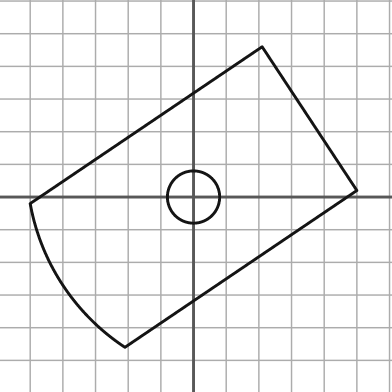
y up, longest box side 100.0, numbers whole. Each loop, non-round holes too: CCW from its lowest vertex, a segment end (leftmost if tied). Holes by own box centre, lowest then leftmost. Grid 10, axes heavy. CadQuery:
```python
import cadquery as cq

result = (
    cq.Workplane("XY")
    .moveTo(-21.0, -46.0)
    .lineTo(50.0, 2.0)
    .lineTo(21.0, 46.0)
    .lineTo(-50.0, -2.0)
    .threePointArc((-40.0, -27.0), (-21.0, -46.0))
    .close()
    .moveTo(0.0, 0.0)
    .circle(8.0)
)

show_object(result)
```